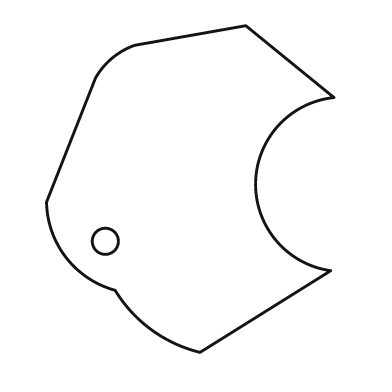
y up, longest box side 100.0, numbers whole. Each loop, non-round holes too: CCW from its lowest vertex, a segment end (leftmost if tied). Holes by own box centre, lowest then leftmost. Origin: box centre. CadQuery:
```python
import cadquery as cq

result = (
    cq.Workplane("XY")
    .moveTo(3.0, -50.0)
    .lineTo(43.0, -25.0)
    .threePointArc((20.0, 2.0), (44.0, 28.0))
    .lineTo(17.0, 50.0)
    .lineTo(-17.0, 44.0)
    .threePointArc((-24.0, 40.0), (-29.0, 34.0))
    .lineTo(-44.0, -4.0)
    .threePointArc((-38.0, -21.0), (-23.0, -31.0))
    .threePointArc((-12.0, -43.0), (3.0, -50.0))
    .close()
    .moveTo(-26.0, -16.0)
    .circle(4.0)
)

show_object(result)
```